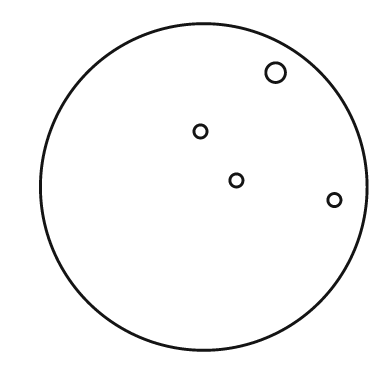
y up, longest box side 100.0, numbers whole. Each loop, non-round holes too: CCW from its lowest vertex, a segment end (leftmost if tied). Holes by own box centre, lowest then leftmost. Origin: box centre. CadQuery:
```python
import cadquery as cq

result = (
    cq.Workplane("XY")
    .moveTo(0.0, 0.0)
    .circle(50.0)
    .moveTo(40.0, -4.0)
    .circle(2.0)
    .moveTo(10.0, 2.0)
    .circle(2.0)
    .moveTo(-1.0, 17.0)
    .circle(2.0)
    .moveTo(22.0, 35.0)
    .circle(3.0)
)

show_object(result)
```